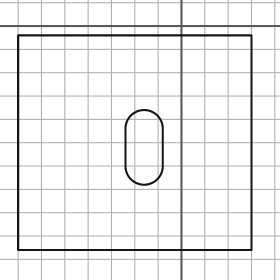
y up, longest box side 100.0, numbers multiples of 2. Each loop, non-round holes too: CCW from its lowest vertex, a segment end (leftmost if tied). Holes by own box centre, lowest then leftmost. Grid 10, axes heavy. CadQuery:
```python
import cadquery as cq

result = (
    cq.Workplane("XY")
    .moveTo(-70.0, -96.0)
    .lineTo(30.0, -96.0)
    .lineTo(30.0, -4.0)
    .lineTo(-70.0, -4.0)
    .close()
    .moveTo(-24.0, -60.0)
    .threePointArc((-16.0, -68.0), (-8.0, -60.0))
    .lineTo(-8.0, -44.0)
    .threePointArc((-16.0, -36.0), (-24.0, -44.0))
    .close()
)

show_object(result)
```